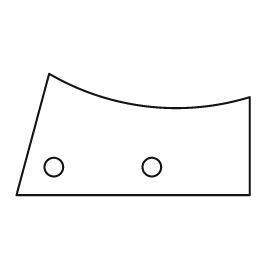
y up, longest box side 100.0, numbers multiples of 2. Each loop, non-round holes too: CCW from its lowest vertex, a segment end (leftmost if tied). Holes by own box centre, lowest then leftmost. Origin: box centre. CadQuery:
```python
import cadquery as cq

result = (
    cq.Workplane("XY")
    .moveTo(-50.0, -26.0)
    .lineTo(50.0, -26.0)
    .lineTo(50.0, 16.0)
    .threePointArc((6.0, 12.0), (-36.0, 26.0))
    .close()
    .moveTo(-34.0, -14.0)
    .circle(4.0)
    .moveTo(8.0, -14.0)
    .circle(4.0)
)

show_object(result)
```